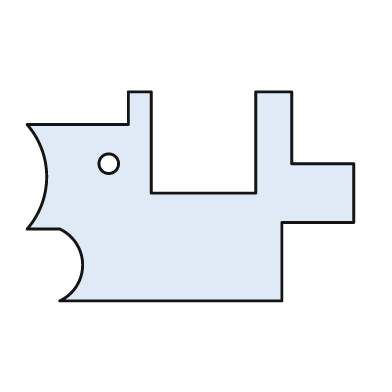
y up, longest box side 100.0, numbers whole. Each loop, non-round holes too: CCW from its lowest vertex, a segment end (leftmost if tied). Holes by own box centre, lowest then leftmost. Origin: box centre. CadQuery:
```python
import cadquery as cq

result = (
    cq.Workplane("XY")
    .moveTo(-40.0, -32.0)
    .lineTo(28.0, -32.0)
    .lineTo(28.0, -8.0)
    .lineTo(50.0, -8.0)
    .lineTo(50.0, 10.0)
    .lineTo(31.0, 10.0)
    .lineTo(31.0, 32.0)
    .lineTo(20.0, 32.0)
    .lineTo(20.0, 1.0)
    .lineTo(-12.0, 1.0)
    .lineTo(-12.0, 32.0)
    .lineTo(-19.0, 32.0)
    .lineTo(-19.0, 22.0)
    .lineTo(-50.0, 22.0)
    .threePointArc((-44.0, 6.0), (-50.0, -10.0))
    .lineTo(-40.0, -10.0)
    .threePointArc((-33.0, -21.0), (-40.0, -32.0))
    .close()
    .moveTo(-25.0, 10.0)
    .circle(3.0)
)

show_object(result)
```